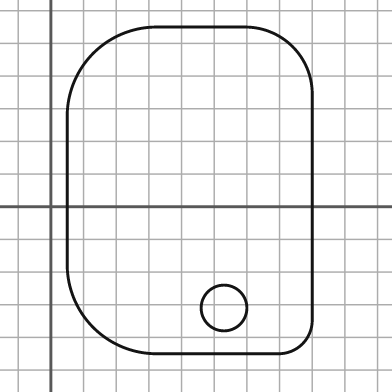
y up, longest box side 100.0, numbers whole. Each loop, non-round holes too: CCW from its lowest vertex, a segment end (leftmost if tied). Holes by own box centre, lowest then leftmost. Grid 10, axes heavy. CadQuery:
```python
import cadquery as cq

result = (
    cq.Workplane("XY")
    .moveTo(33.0, -45.0)
    .lineTo(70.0, -45.0)
    .threePointArc((77.0, -42.0), (80.0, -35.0))
    .lineTo(80.0, 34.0)
    .threePointArc((74.0, 49.0), (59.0, 55.0))
    .lineTo(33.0, 55.0)
    .threePointArc((13.0, 47.0), (5.0, 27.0))
    .lineTo(5.0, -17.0)
    .threePointArc((13.0, -37.0), (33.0, -45.0))
    .close()
    .moveTo(53.0, -31.0)
    .circle(7.0)
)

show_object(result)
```